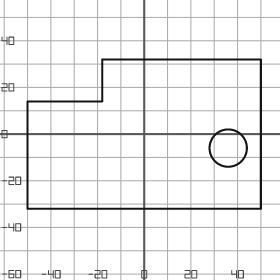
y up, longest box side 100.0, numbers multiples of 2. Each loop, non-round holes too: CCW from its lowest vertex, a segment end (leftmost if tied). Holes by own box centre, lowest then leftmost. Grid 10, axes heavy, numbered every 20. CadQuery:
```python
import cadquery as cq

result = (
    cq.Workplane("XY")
    .moveTo(-50.0, -32.0)
    .lineTo(50.0, -32.0)
    .lineTo(50.0, 32.0)
    .lineTo(-18.0, 32.0)
    .lineTo(-18.0, 14.0)
    .lineTo(-50.0, 14.0)
    .close()
    .moveTo(36.0, -6.0)
    .circle(8.0)
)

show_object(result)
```